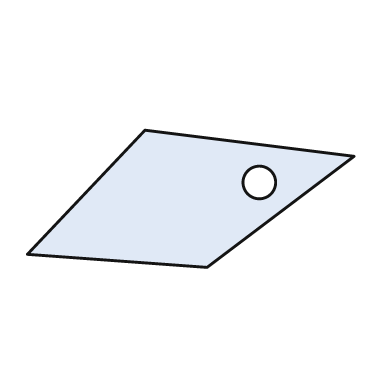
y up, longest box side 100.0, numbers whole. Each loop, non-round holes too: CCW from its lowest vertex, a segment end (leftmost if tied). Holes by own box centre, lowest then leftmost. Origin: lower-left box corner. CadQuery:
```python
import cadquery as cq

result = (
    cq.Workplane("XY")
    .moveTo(55.0, 0.0)
    .lineTo(100.0, 34.0)
    .lineTo(36.0, 42.0)
    .lineTo(0.0, 4.0)
    .close()
    .moveTo(71.0, 26.0)
    .circle(5.0)
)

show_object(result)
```